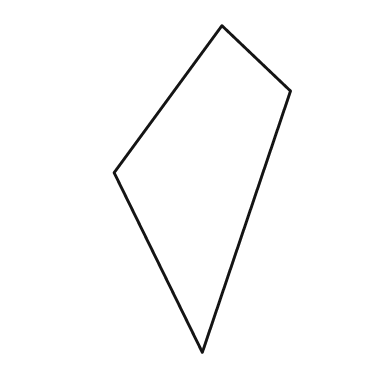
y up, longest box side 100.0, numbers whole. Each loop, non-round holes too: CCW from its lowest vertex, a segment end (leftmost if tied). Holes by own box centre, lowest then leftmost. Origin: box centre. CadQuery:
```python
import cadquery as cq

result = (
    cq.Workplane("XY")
    .moveTo(0.0, -50.0)
    .lineTo(27.0, 30.0)
    .lineTo(6.0, 50.0)
    .lineTo(-27.0, 5.0)
    .close()
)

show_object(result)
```